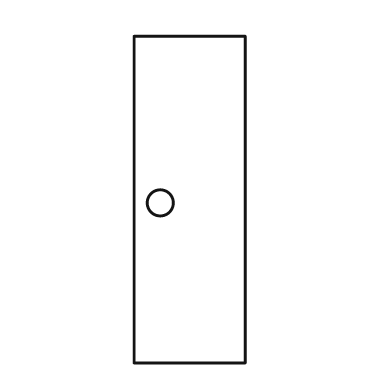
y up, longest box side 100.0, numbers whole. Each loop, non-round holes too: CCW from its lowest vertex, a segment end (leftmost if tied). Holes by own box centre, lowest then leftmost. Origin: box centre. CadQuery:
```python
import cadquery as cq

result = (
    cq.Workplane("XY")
    .moveTo(-17.0, -50.0)
    .lineTo(17.0, -50.0)
    .lineTo(17.0, 50.0)
    .lineTo(-17.0, 50.0)
    .close()
    .moveTo(-9.0, -1.0)
    .circle(4.0)
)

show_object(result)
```